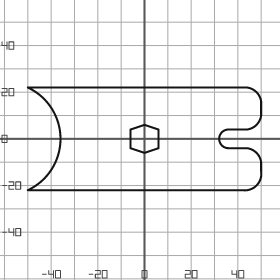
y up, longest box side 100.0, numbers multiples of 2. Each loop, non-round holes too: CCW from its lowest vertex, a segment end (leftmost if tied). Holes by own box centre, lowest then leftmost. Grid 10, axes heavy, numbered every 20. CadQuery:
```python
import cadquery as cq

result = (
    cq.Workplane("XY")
    .moveTo(-50.0, -22.0)
    .lineTo(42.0, -22.0)
    .threePointArc((48.0, -20.0), (50.0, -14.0))
    .lineTo(50.0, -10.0)
    .threePointArc((48.0, -6.0), (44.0, -4.0))
    .lineTo(36.0, -4.0)
    .threePointArc((32.0, 0.0), (36.0, 4.0))
    .lineTo(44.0, 4.0)
    .threePointArc((48.0, 6.0), (50.0, 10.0))
    .lineTo(50.0, 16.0)
    .threePointArc((48.0, 20.0), (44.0, 22.0))
    .lineTo(-50.0, 22.0)
    .threePointArc((-36.0, 0.0), (-50.0, -22.0))
    .close()
    .moveTo(0.0, -6.0)
    .lineTo(6.0, -4.0)
    .lineTo(6.0, 4.0)
    .lineTo(0.0, 6.0)
    .lineTo(-6.0, 4.0)
    .lineTo(-6.0, -4.0)
    .close()
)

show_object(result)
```